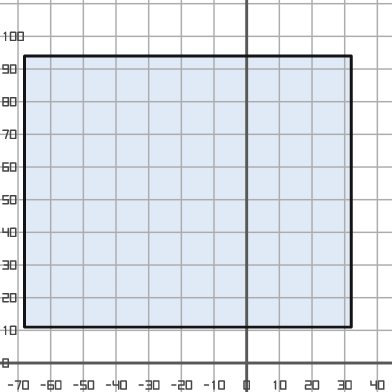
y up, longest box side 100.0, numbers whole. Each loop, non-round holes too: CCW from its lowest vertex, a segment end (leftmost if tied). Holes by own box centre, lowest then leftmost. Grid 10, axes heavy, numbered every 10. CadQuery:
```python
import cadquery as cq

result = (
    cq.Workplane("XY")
    .moveTo(-68.0, 11.0)
    .lineTo(32.0, 11.0)
    .lineTo(32.0, 94.0)
    .lineTo(-68.0, 94.0)
    .close()
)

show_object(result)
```